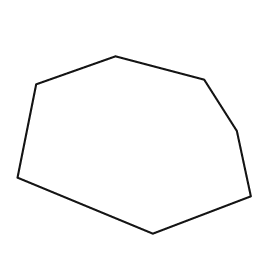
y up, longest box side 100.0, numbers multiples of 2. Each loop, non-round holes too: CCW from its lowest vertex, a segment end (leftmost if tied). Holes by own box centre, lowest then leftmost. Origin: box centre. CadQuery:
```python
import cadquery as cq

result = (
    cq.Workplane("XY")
    .moveTo(8.0, -38.0)
    .lineTo(50.0, -22.0)
    .lineTo(44.0, 6.0)
    .lineTo(30.0, 28.0)
    .lineTo(-8.0, 38.0)
    .lineTo(-42.0, 26.0)
    .lineTo(-50.0, -14.0)
    .close()
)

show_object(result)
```